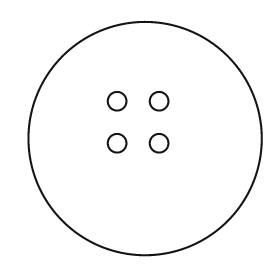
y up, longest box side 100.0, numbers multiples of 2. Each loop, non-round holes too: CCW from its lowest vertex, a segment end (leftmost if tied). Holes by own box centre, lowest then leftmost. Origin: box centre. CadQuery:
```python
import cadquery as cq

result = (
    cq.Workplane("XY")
    .moveTo(0.0, 0.0)
    .circle(50.0)
    .moveTo(-12.0, -2.0)
    .circle(4.0)
    .moveTo(6.0, -2.0)
    .circle(4.0)
    .moveTo(-12.0, 16.0)
    .circle(4.0)
    .moveTo(6.0, 16.0)
    .circle(4.0)
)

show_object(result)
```